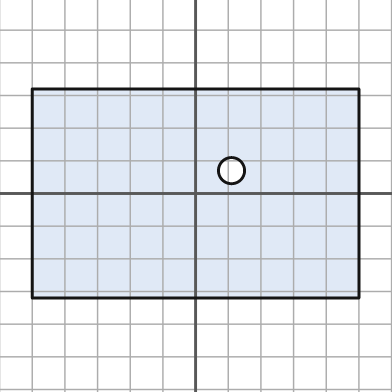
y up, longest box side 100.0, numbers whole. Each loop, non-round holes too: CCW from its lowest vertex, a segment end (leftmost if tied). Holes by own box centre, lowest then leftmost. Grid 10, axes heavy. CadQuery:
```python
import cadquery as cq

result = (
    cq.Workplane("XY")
    .moveTo(-50.0, -32.0)
    .lineTo(50.0, -32.0)
    .lineTo(50.0, 32.0)
    .lineTo(-50.0, 32.0)
    .close()
    .moveTo(11.0, 7.0)
    .circle(4.0)
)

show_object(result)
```